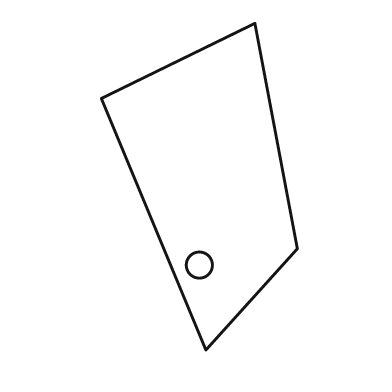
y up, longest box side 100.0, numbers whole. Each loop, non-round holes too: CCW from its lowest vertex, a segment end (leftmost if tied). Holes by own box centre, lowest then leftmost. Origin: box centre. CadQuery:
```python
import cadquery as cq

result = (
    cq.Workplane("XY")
    .moveTo(2.0, -50.0)
    .lineTo(30.0, -19.0)
    .lineTo(17.0, 50.0)
    .lineTo(-30.0, 27.0)
    .close()
    .moveTo(0.0, -24.0)
    .circle(4.0)
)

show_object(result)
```